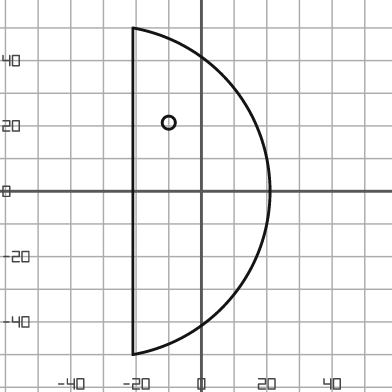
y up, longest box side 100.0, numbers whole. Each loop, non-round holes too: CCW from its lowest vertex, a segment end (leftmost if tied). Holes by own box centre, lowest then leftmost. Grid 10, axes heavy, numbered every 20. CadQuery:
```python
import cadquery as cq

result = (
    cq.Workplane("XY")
    .moveTo(-21.0, -50.0)
    .threePointArc((21.0, 0.0), (-21.0, 50.0))
    .close()
    .moveTo(-10.0, 21.0)
    .circle(2.0)
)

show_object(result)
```